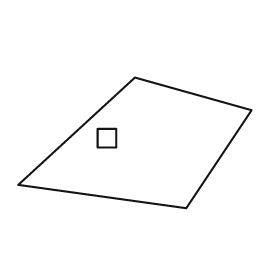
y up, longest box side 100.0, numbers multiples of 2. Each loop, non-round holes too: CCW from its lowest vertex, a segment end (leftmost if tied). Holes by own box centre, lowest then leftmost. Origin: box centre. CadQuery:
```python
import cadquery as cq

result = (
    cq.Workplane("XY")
    .moveTo(22.0, -28.0)
    .lineTo(50.0, 14.0)
    .lineTo(0.0, 28.0)
    .lineTo(-50.0, -18.0)
    .close()
    .moveTo(-16.0, -2.0)
    .lineTo(-8.0, -2.0)
    .lineTo(-8.0, 6.0)
    .lineTo(-16.0, 6.0)
    .close()
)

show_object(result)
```